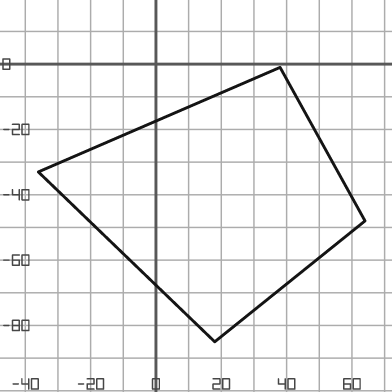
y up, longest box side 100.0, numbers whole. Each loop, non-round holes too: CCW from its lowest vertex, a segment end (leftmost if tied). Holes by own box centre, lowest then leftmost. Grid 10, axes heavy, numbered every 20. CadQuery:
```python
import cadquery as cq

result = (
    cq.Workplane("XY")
    .moveTo(18.0, -85.0)
    .lineTo(64.0, -48.0)
    .lineTo(38.0, -1.0)
    .lineTo(-36.0, -33.0)
    .close()
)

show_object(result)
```